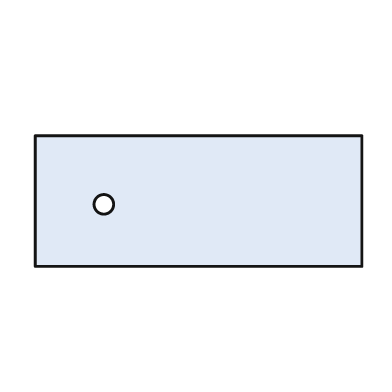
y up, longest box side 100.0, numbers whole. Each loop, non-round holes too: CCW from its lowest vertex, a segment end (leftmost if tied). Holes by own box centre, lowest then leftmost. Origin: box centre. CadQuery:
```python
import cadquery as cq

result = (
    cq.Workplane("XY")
    .moveTo(-50.0, -20.0)
    .lineTo(50.0, -20.0)
    .lineTo(50.0, 20.0)
    .lineTo(-50.0, 20.0)
    .close()
    .moveTo(-29.0, -1.0)
    .circle(3.0)
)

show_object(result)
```